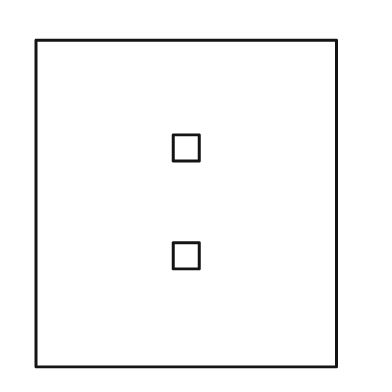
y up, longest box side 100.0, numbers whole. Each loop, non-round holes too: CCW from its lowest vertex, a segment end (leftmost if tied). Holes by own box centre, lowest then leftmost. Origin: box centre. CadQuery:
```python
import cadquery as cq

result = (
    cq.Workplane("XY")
    .moveTo(-46.0, -50.0)
    .lineTo(46.0, -50.0)
    .lineTo(46.0, 50.0)
    .lineTo(-46.0, 50.0)
    .close()
    .moveTo(-4.0, -20.0)
    .lineTo(4.0, -20.0)
    .lineTo(4.0, -12.0)
    .lineTo(-4.0, -12.0)
    .close()
    .moveTo(-4.0, 13.0)
    .lineTo(4.0, 13.0)
    .lineTo(4.0, 21.0)
    .lineTo(-4.0, 21.0)
    .close()
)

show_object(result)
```